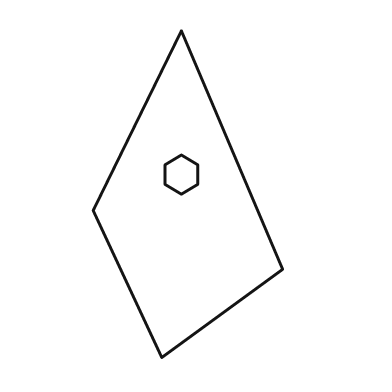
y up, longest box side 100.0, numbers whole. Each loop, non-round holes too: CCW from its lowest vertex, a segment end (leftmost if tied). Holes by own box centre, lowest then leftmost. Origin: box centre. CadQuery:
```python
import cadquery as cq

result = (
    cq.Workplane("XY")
    .moveTo(-8.0, -50.0)
    .lineTo(29.0, -23.0)
    .lineTo(-2.0, 50.0)
    .lineTo(-29.0, -5.0)
    .close()
    .moveTo(-2.0, 0.0)
    .lineTo(3.0, 3.0)
    .lineTo(3.0, 9.0)
    .lineTo(-2.0, 12.0)
    .lineTo(-7.0, 9.0)
    .lineTo(-7.0, 3.0)
    .close()
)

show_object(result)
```